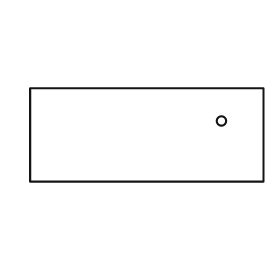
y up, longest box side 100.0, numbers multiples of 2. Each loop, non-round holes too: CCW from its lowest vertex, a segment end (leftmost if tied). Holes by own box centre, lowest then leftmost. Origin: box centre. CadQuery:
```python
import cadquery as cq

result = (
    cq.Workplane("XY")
    .moveTo(-50.0, -20.0)
    .lineTo(50.0, -20.0)
    .lineTo(50.0, 20.0)
    .lineTo(-50.0, 20.0)
    .close()
    .moveTo(32.0, 6.0)
    .circle(2.0)
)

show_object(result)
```